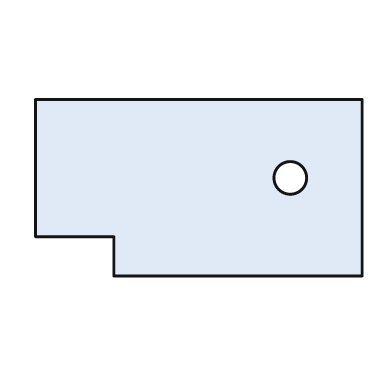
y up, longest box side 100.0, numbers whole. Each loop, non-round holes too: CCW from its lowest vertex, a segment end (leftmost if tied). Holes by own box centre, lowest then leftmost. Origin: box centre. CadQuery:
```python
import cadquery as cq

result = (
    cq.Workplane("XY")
    .moveTo(-26.0, -27.0)
    .lineTo(50.0, -27.0)
    .lineTo(50.0, 27.0)
    .lineTo(-50.0, 27.0)
    .lineTo(-50.0, -15.0)
    .lineTo(-26.0, -15.0)
    .close()
    .moveTo(28.0, 3.0)
    .circle(5.0)
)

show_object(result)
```